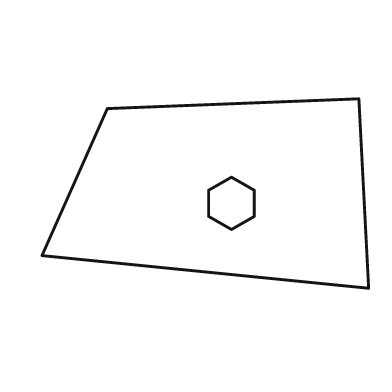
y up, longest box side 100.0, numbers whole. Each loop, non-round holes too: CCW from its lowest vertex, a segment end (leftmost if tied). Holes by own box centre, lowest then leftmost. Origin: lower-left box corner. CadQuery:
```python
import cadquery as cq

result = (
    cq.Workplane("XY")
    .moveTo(100.0, 0.0)
    .lineTo(97.0, 58.0)
    .lineTo(20.0, 55.0)
    .lineTo(0.0, 10.0)
    .close()
    .moveTo(58.0, 18.0)
    .lineTo(65.0, 22.0)
    .lineTo(65.0, 30.0)
    .lineTo(58.0, 34.0)
    .lineTo(51.0, 30.0)
    .lineTo(51.0, 22.0)
    .close()
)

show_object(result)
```